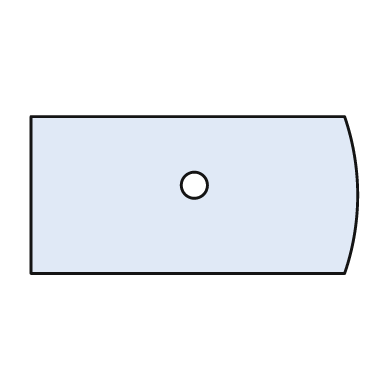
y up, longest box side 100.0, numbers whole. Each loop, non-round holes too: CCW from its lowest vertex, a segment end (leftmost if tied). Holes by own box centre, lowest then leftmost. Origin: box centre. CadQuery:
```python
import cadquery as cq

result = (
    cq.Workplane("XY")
    .moveTo(-50.0, -24.0)
    .lineTo(46.0, -24.0)
    .threePointArc((50.0, 0.0), (46.0, 24.0))
    .lineTo(-50.0, 24.0)
    .close()
    .moveTo(0.0, 3.0)
    .circle(4.0)
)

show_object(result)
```